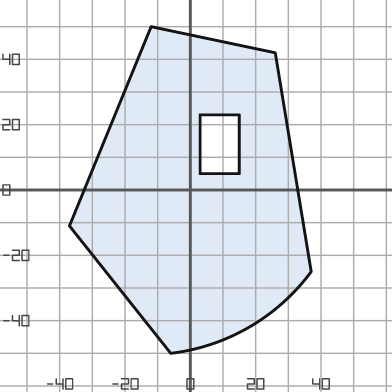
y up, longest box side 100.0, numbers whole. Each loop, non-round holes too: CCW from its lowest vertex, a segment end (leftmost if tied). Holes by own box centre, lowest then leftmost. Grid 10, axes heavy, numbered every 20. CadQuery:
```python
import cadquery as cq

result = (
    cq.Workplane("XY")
    .moveTo(-6.0, -50.0)
    .threePointArc((18.0, -42.0), (37.0, -25.0))
    .lineTo(26.0, 42.0)
    .lineTo(-12.0, 50.0)
    .lineTo(-37.0, -11.0)
    .close()
    .moveTo(3.0, 5.0)
    .lineTo(15.0, 5.0)
    .lineTo(15.0, 23.0)
    .lineTo(3.0, 23.0)
    .close()
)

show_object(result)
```